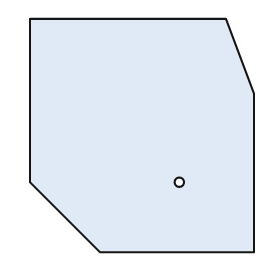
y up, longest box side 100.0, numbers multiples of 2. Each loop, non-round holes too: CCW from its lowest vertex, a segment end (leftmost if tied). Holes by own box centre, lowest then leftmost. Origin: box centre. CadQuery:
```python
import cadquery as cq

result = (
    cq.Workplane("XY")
    .moveTo(-18.0, -50.0)
    .lineTo(48.0, -50.0)
    .lineTo(48.0, 18.0)
    .lineTo(36.0, 50.0)
    .lineTo(-48.0, 50.0)
    .lineTo(-48.0, -20.0)
    .close()
    .moveTo(16.0, -20.0)
    .circle(2.0)
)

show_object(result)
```